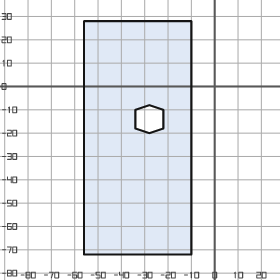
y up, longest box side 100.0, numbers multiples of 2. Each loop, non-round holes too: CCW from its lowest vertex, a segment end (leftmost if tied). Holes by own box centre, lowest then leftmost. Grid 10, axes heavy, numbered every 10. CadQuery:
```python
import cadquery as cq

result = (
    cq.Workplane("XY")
    .moveTo(-56.0, -72.0)
    .lineTo(-10.0, -72.0)
    .lineTo(-10.0, 28.0)
    .lineTo(-56.0, 28.0)
    .close()
    .moveTo(-28.0, -20.0)
    .lineTo(-22.0, -18.0)
    .lineTo(-22.0, -10.0)
    .lineTo(-28.0, -8.0)
    .lineTo(-34.0, -10.0)
    .lineTo(-34.0, -18.0)
    .close()
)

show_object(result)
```